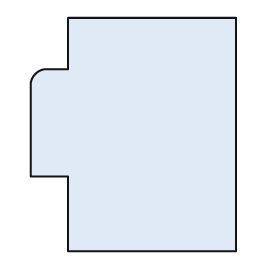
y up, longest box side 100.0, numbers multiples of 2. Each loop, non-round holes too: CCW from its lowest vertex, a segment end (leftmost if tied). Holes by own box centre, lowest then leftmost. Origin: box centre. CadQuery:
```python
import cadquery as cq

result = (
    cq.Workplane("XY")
    .moveTo(-28.0, -50.0)
    .lineTo(44.0, -50.0)
    .lineTo(44.0, 50.0)
    .lineTo(-28.0, 50.0)
    .lineTo(-28.0, 28.0)
    .lineTo(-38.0, 28.0)
    .threePointArc((-42.0, 26.0), (-44.0, 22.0))
    .lineTo(-44.0, -18.0)
    .lineTo(-28.0, -18.0)
    .close()
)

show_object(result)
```